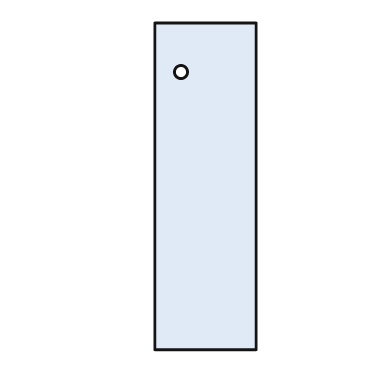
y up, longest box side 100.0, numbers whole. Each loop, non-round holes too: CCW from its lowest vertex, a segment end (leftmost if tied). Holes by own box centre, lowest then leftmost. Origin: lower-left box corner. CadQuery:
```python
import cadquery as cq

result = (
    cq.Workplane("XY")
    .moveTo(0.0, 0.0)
    .lineTo(31.0, 0.0)
    .lineTo(31.0, 100.0)
    .lineTo(0.0, 100.0)
    .close()
    .moveTo(8.0, 85.0)
    .circle(2.0)
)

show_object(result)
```